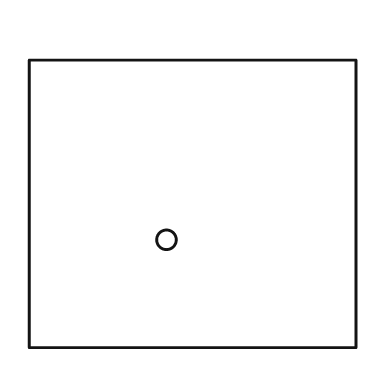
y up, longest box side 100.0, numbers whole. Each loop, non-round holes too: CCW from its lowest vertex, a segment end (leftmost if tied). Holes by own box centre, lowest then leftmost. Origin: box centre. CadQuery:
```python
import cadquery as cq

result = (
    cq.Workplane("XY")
    .moveTo(-50.0, -44.0)
    .lineTo(50.0, -44.0)
    .lineTo(50.0, 44.0)
    .lineTo(-50.0, 44.0)
    .close()
    .moveTo(-8.0, -11.0)
    .circle(3.0)
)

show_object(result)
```